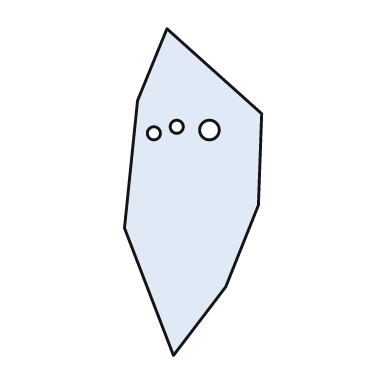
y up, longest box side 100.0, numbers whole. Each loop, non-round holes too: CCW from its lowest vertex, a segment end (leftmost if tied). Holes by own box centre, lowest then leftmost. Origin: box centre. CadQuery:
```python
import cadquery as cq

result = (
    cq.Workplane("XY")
    .moveTo(-6.0, -50.0)
    .lineTo(10.0, -29.0)
    .lineTo(20.0, -4.0)
    .lineTo(21.0, 24.0)
    .lineTo(-8.0, 50.0)
    .lineTo(-17.0, 28.0)
    .lineTo(-21.0, -11.0)
    .close()
    .moveTo(-12.0, 18.0)
    .circle(2.0)
    .moveTo(5.0, 19.0)
    .circle(3.0)
    .moveTo(-5.0, 20.0)
    .circle(2.0)
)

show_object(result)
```